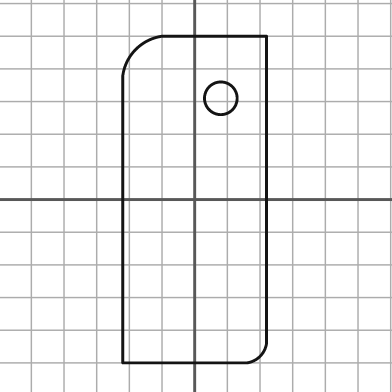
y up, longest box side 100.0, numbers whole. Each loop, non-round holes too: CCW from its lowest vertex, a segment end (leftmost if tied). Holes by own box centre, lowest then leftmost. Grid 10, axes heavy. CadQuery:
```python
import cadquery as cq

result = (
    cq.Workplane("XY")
    .moveTo(-22.0, -50.0)
    .lineTo(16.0, -50.0)
    .threePointArc((20.0, -48.0), (22.0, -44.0))
    .lineTo(22.0, 50.0)
    .lineTo(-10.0, 50.0)
    .threePointArc((-18.0, 46.0), (-22.0, 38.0))
    .close()
    .moveTo(8.0, 31.0)
    .circle(5.0)
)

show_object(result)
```